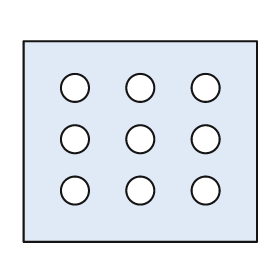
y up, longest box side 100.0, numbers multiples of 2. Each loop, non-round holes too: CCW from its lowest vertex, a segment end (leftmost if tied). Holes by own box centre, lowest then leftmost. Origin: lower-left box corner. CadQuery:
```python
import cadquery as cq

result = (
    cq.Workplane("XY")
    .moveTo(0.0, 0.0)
    .lineTo(100.0, 0.0)
    .lineTo(100.0, 86.0)
    .lineTo(0.0, 86.0)
    .close()
    .moveTo(22.0, 22.0)
    .circle(6.0)
    .moveTo(50.0, 22.0)
    .circle(6.0)
    .moveTo(78.0, 22.0)
    .circle(6.0)
    .moveTo(22.0, 44.0)
    .circle(6.0)
    .moveTo(50.0, 44.0)
    .circle(6.0)
    .moveTo(78.0, 44.0)
    .circle(6.0)
    .moveTo(22.0, 66.0)
    .circle(6.0)
    .moveTo(50.0, 66.0)
    .circle(6.0)
    .moveTo(78.0, 66.0)
    .circle(6.0)
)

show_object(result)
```